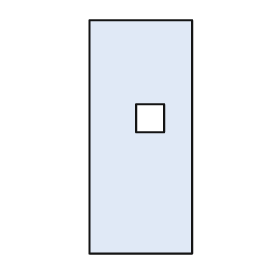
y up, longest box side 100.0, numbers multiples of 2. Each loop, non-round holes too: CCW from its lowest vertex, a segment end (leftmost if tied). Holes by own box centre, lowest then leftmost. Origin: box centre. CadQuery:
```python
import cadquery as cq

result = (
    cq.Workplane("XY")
    .moveTo(-22.0, -50.0)
    .lineTo(22.0, -50.0)
    .lineTo(22.0, 50.0)
    .lineTo(-22.0, 50.0)
    .close()
    .moveTo(-2.0, 2.0)
    .lineTo(10.0, 2.0)
    .lineTo(10.0, 14.0)
    .lineTo(-2.0, 14.0)
    .close()
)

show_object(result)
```